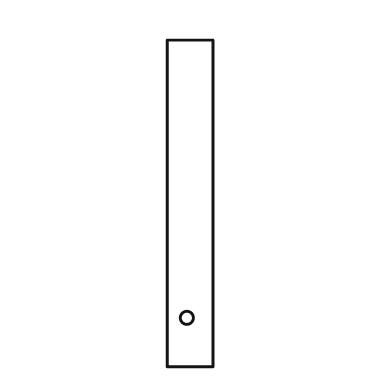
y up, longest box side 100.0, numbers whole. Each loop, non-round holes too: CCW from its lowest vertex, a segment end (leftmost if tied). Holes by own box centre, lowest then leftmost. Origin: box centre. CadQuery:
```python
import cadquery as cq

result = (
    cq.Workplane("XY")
    .moveTo(-7.0, -50.0)
    .lineTo(7.0, -50.0)
    .lineTo(7.0, 50.0)
    .lineTo(-7.0, 50.0)
    .close()
    .moveTo(-1.0, -35.0)
    .circle(2.0)
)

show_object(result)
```